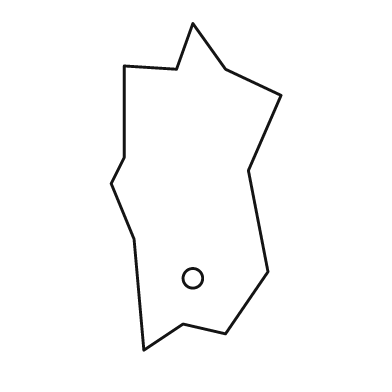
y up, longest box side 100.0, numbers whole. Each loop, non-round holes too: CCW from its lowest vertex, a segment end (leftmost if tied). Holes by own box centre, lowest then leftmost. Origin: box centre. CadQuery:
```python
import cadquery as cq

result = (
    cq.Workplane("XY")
    .moveTo(-16.0, -50.0)
    .lineTo(-4.0, -42.0)
    .lineTo(9.0, -45.0)
    .lineTo(22.0, -26.0)
    .lineTo(16.0, 5.0)
    .lineTo(26.0, 28.0)
    .lineTo(9.0, 36.0)
    .lineTo(-1.0, 50.0)
    .lineTo(-6.0, 36.0)
    .lineTo(-22.0, 37.0)
    .lineTo(-22.0, 9.0)
    .lineTo(-26.0, 1.0)
    .lineTo(-19.0, -16.0)
    .close()
    .moveTo(-1.0, -28.0)
    .circle(3.0)
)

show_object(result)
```